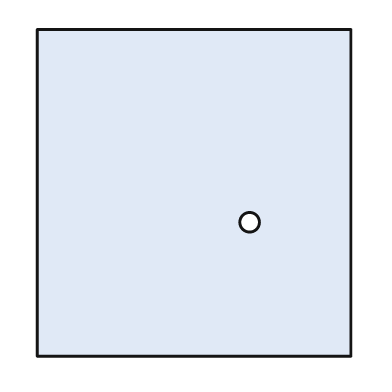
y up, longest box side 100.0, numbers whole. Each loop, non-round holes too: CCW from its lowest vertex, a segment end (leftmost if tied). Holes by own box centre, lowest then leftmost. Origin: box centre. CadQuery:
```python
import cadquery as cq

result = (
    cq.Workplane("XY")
    .moveTo(-48.0, -50.0)
    .lineTo(48.0, -50.0)
    .lineTo(48.0, 50.0)
    .lineTo(-48.0, 50.0)
    .close()
    .moveTo(17.0, -9.0)
    .circle(3.0)
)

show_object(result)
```